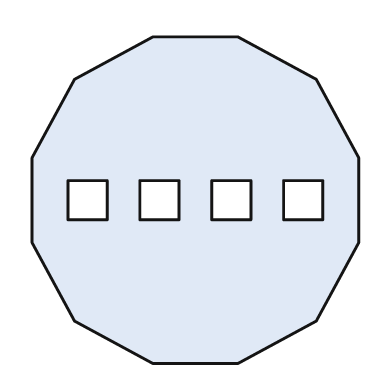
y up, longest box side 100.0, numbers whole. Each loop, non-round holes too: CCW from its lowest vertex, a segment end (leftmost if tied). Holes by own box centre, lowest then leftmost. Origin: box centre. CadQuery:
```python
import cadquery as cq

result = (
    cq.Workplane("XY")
    .moveTo(-13.0, -50.0)
    .lineTo(13.0, -50.0)
    .lineTo(37.0, -37.0)
    .lineTo(50.0, -13.0)
    .lineTo(50.0, 13.0)
    .lineTo(37.0, 37.0)
    .lineTo(13.0, 50.0)
    .lineTo(-13.0, 50.0)
    .lineTo(-37.0, 37.0)
    .lineTo(-50.0, 13.0)
    .lineTo(-50.0, -13.0)
    .lineTo(-37.0, -37.0)
    .close()
    .moveTo(-39.0, -6.0)
    .lineTo(-27.0, -6.0)
    .lineTo(-27.0, 6.0)
    .lineTo(-39.0, 6.0)
    .close()
    .moveTo(-17.0, -6.0)
    .lineTo(-5.0, -6.0)
    .lineTo(-5.0, 6.0)
    .lineTo(-17.0, 6.0)
    .close()
    .moveTo(5.0, -6.0)
    .lineTo(17.0, -6.0)
    .lineTo(17.0, 6.0)
    .lineTo(5.0, 6.0)
    .close()
    .moveTo(27.0, -6.0)
    .lineTo(39.0, -6.0)
    .lineTo(39.0, 6.0)
    .lineTo(27.0, 6.0)
    .close()
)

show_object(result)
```